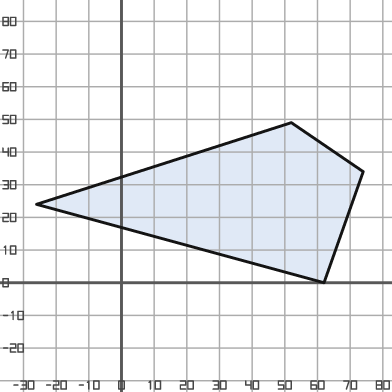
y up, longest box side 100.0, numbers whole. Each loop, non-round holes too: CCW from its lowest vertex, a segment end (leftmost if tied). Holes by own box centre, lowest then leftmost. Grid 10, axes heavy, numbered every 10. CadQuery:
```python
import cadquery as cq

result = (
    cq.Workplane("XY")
    .moveTo(62.0, 0.0)
    .lineTo(74.0, 34.0)
    .lineTo(52.0, 49.0)
    .lineTo(-26.0, 24.0)
    .close()
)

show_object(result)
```